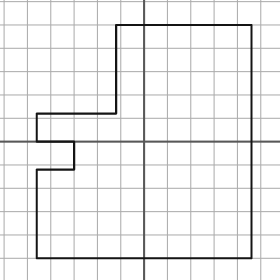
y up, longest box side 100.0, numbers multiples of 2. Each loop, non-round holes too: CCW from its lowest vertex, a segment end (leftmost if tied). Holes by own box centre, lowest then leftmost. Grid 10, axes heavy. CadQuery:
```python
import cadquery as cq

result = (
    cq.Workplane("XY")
    .moveTo(-46.0, -50.0)
    .lineTo(46.0, -50.0)
    .lineTo(46.0, 50.0)
    .lineTo(-12.0, 50.0)
    .lineTo(-12.0, 12.0)
    .lineTo(-46.0, 12.0)
    .lineTo(-46.0, 0.0)
    .lineTo(-30.0, 0.0)
    .lineTo(-30.0, -12.0)
    .lineTo(-46.0, -12.0)
    .close()
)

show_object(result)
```